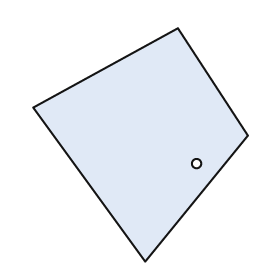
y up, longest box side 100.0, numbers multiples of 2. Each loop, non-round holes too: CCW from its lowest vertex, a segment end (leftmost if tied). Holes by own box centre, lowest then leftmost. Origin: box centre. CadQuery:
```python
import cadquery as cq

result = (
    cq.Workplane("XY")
    .moveTo(2.0, -50.0)
    .lineTo(46.0, 4.0)
    .lineTo(16.0, 50.0)
    .lineTo(-46.0, 16.0)
    .close()
    .moveTo(24.0, -8.0)
    .circle(2.0)
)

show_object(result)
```